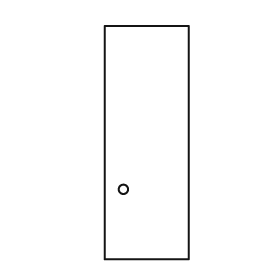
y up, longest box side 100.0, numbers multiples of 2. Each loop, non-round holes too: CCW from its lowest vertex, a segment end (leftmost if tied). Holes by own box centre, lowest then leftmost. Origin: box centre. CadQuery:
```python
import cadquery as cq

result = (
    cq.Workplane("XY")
    .moveTo(-18.0, -50.0)
    .lineTo(18.0, -50.0)
    .lineTo(18.0, 50.0)
    .lineTo(-18.0, 50.0)
    .close()
    .moveTo(-10.0, -20.0)
    .circle(2.0)
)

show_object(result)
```